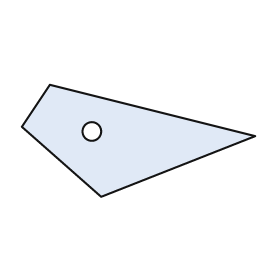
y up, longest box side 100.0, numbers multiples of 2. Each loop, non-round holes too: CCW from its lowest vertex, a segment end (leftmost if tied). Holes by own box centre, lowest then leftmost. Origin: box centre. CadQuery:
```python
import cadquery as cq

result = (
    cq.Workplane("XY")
    .moveTo(-16.0, -24.0)
    .lineTo(50.0, 2.0)
    .lineTo(-38.0, 24.0)
    .lineTo(-50.0, 6.0)
    .close()
    .moveTo(-20.0, 4.0)
    .circle(4.0)
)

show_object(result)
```